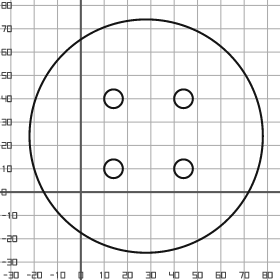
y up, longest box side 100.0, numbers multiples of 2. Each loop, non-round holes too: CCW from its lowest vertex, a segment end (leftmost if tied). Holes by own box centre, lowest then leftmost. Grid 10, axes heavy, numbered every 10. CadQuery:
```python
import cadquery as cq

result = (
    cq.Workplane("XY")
    .moveTo(28.0, 24.0)
    .circle(50.0)
    .moveTo(14.0, 10.0)
    .circle(4.0)
    .moveTo(44.0, 10.0)
    .circle(4.0)
    .moveTo(14.0, 40.0)
    .circle(4.0)
    .moveTo(44.0, 40.0)
    .circle(4.0)
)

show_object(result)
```